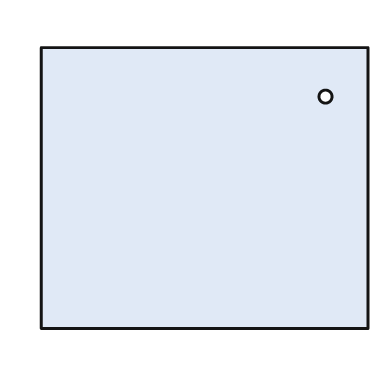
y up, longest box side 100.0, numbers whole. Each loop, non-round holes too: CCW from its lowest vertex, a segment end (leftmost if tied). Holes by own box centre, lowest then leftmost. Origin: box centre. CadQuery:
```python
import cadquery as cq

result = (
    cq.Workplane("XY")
    .moveTo(-50.0, -43.0)
    .lineTo(50.0, -43.0)
    .lineTo(50.0, 43.0)
    .lineTo(-50.0, 43.0)
    .close()
    .moveTo(37.0, 28.0)
    .circle(2.0)
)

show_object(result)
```